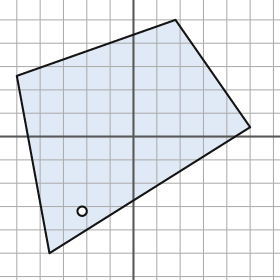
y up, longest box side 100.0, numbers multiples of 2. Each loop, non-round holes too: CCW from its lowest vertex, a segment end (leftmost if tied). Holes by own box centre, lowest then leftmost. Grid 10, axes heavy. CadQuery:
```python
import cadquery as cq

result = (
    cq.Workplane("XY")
    .moveTo(-36.0, -50.0)
    .lineTo(50.0, 4.0)
    .lineTo(18.0, 50.0)
    .lineTo(-50.0, 26.0)
    .close()
    .moveTo(-22.0, -32.0)
    .circle(2.0)
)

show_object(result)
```